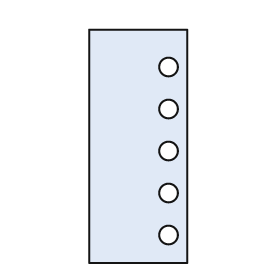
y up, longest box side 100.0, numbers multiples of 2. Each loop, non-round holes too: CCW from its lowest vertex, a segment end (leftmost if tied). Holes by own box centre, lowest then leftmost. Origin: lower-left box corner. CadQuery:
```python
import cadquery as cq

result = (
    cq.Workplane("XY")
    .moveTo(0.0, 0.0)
    .lineTo(42.0, 0.0)
    .lineTo(42.0, 100.0)
    .lineTo(0.0, 100.0)
    .close()
    .moveTo(34.0, 12.0)
    .circle(4.0)
    .moveTo(34.0, 30.0)
    .circle(4.0)
    .moveTo(34.0, 48.0)
    .circle(4.0)
    .moveTo(34.0, 66.0)
    .circle(4.0)
    .moveTo(34.0, 84.0)
    .circle(4.0)
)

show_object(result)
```